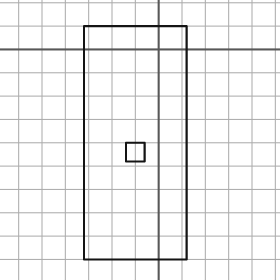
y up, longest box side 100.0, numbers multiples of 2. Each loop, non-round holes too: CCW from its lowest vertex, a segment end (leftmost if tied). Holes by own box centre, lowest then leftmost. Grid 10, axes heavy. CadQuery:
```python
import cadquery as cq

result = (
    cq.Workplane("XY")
    .moveTo(-32.0, -90.0)
    .lineTo(12.0, -90.0)
    .lineTo(12.0, 10.0)
    .lineTo(-32.0, 10.0)
    .close()
    .moveTo(-14.0, -48.0)
    .lineTo(-6.0, -48.0)
    .lineTo(-6.0, -40.0)
    .lineTo(-14.0, -40.0)
    .close()
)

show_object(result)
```